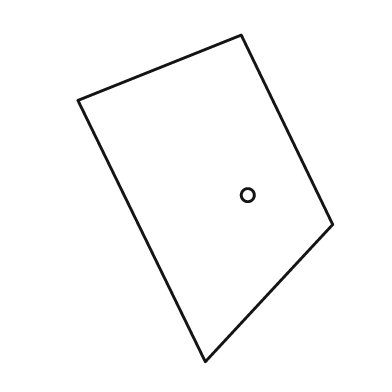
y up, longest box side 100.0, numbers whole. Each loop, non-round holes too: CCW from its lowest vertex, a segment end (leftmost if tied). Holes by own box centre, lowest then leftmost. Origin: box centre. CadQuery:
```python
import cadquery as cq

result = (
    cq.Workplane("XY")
    .moveTo(0.0, -50.0)
    .lineTo(39.0, -8.0)
    .lineTo(11.0, 50.0)
    .lineTo(-39.0, 30.0)
    .close()
    .moveTo(13.0, 1.0)
    .circle(2.0)
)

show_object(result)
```